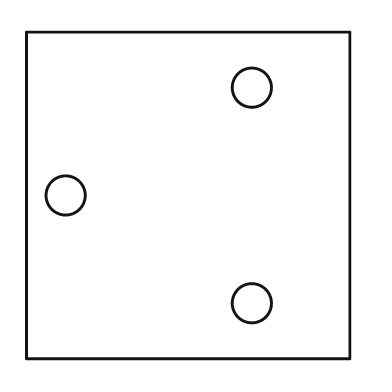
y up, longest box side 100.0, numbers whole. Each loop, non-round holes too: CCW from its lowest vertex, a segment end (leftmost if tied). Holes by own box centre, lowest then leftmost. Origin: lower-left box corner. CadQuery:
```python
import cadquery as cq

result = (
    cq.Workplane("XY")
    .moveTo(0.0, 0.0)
    .lineTo(99.0, 0.0)
    .lineTo(99.0, 100.0)
    .lineTo(0.0, 100.0)
    .close()
    .moveTo(69.0, 17.0)
    .circle(6.0)
    .moveTo(12.0, 50.0)
    .circle(6.0)
    .moveTo(69.0, 83.0)
    .circle(6.0)
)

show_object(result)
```